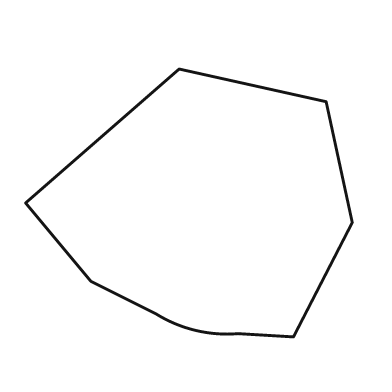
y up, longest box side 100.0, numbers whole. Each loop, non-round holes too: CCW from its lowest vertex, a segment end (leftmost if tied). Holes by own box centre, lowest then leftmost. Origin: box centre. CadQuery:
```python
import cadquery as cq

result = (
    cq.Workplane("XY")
    .moveTo(32.0, -41.0)
    .lineTo(50.0, -6.0)
    .lineTo(42.0, 31.0)
    .lineTo(-3.0, 41.0)
    .lineTo(-50.0, 0.0)
    .lineTo(-30.0, -24.0)
    .lineTo(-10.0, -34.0)
    .threePointArc((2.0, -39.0), (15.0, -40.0))
    .close()
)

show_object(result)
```